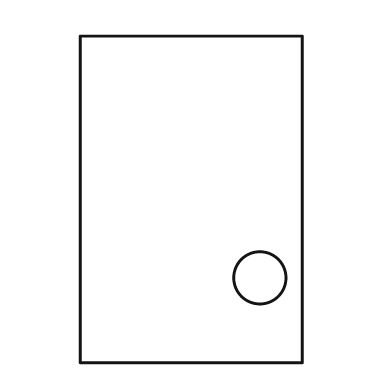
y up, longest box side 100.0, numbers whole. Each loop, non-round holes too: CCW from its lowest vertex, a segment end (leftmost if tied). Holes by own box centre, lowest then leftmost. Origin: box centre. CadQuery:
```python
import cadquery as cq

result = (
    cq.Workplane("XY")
    .moveTo(-34.0, -50.0)
    .lineTo(34.0, -50.0)
    .lineTo(34.0, 50.0)
    .lineTo(-34.0, 50.0)
    .close()
    .moveTo(21.0, -24.0)
    .circle(8.0)
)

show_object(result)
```